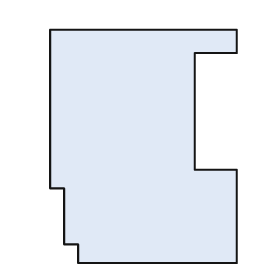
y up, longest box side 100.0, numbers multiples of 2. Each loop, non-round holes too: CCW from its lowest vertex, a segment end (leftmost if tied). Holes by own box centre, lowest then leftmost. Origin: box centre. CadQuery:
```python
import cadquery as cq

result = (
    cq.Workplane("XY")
    .moveTo(-28.0, -50.0)
    .lineTo(40.0, -50.0)
    .lineTo(40.0, -10.0)
    .lineTo(22.0, -10.0)
    .lineTo(22.0, 40.0)
    .lineTo(40.0, 40.0)
    .lineTo(40.0, 50.0)
    .lineTo(-40.0, 50.0)
    .lineTo(-40.0, -18.0)
    .lineTo(-34.0, -18.0)
    .lineTo(-34.0, -42.0)
    .lineTo(-28.0, -42.0)
    .close()
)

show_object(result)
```